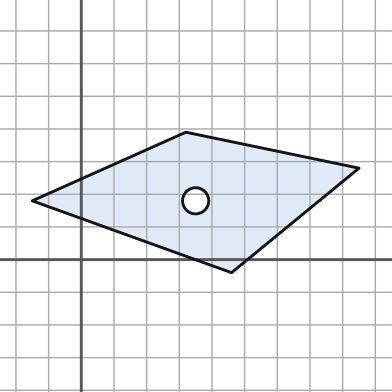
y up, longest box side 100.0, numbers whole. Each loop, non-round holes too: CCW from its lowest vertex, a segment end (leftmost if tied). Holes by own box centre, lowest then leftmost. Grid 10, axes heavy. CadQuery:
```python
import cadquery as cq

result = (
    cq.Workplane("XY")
    .moveTo(46.0, -4.0)
    .lineTo(85.0, 28.0)
    .lineTo(32.0, 39.0)
    .lineTo(-15.0, 18.0)
    .close()
    .moveTo(35.0, 18.0)
    .circle(4.0)
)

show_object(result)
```